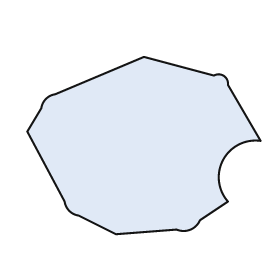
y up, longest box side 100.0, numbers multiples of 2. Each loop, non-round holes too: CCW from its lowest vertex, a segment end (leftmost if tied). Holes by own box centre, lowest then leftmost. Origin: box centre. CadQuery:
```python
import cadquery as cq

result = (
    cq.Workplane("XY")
    .moveTo(-12.0, -38.0)
    .lineTo(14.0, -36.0)
    .threePointArc((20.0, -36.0), (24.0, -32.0))
    .lineTo(36.0, -24.0)
    .threePointArc((34.0, -6.0), (50.0, 2.0))
    .lineTo(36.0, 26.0)
    .threePointArc((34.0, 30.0), (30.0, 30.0))
    .lineTo(0.0, 38.0)
    .lineTo(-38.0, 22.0)
    .threePointArc((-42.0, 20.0), (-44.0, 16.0))
    .lineTo(-50.0, 6.0)
    .lineTo(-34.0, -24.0)
    .threePointArc((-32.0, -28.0), (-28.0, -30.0))
    .close()
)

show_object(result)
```